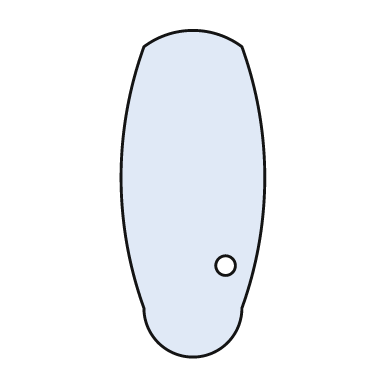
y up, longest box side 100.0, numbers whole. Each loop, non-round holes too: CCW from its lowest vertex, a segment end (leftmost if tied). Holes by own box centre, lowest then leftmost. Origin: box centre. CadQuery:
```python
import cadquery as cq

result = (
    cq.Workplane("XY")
    .moveTo(-15.0, -35.0)
    .threePointArc((0.0, -50.0), (15.0, -35.0))
    .threePointArc((22.0, 5.0), (15.0, 45.0))
    .threePointArc((0.0, 50.0), (-15.0, 45.0))
    .threePointArc((-22.0, 5.0), (-15.0, -35.0))
    .close()
    .moveTo(10.0, -22.0)
    .circle(3.0)
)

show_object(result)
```